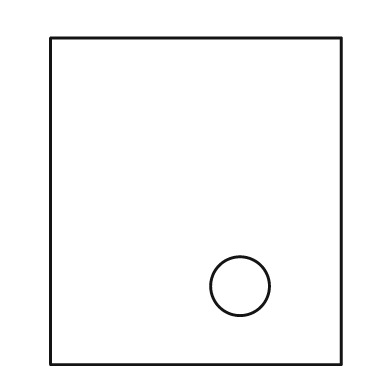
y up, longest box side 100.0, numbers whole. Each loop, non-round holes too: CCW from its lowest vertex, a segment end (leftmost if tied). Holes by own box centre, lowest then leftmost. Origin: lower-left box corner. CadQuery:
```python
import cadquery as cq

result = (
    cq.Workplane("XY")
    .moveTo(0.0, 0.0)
    .lineTo(89.0, 0.0)
    .lineTo(89.0, 100.0)
    .lineTo(0.0, 100.0)
    .close()
    .moveTo(58.0, 24.0)
    .circle(9.0)
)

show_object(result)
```